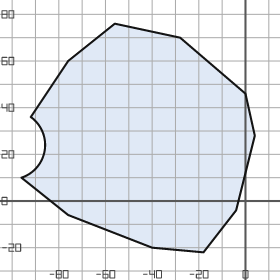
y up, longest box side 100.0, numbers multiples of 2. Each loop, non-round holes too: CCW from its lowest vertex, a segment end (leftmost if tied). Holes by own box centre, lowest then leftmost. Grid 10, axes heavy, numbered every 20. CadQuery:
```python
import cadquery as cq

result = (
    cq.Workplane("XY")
    .moveTo(-18.0, -22.0)
    .lineTo(-4.0, -4.0)
    .lineTo(4.0, 28.0)
    .lineTo(0.0, 46.0)
    .lineTo(-28.0, 70.0)
    .lineTo(-56.0, 76.0)
    .lineTo(-76.0, 60.0)
    .lineTo(-92.0, 36.0)
    .threePointArc((-86.0, 22.0), (-96.0, 10.0))
    .lineTo(-76.0, -6.0)
    .lineTo(-40.0, -20.0)
    .close()
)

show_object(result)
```